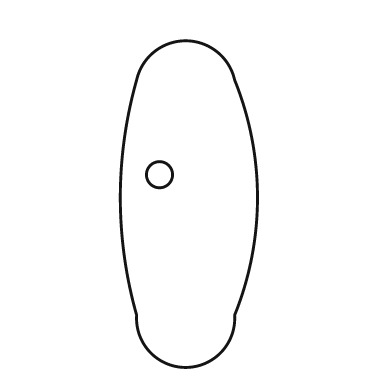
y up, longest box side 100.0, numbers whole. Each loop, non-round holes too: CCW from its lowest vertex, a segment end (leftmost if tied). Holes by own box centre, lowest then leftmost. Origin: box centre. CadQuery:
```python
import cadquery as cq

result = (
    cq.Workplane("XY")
    .moveTo(-16.0, -34.0)
    .threePointArc((-1.0, -50.0), (14.0, -34.0))
    .threePointArc((21.0, 2.0), (14.0, 38.0))
    .threePointArc((-1.0, 50.0), (-16.0, 38.0))
    .threePointArc((-21.0, 2.0), (-16.0, -34.0))
    .close()
    .moveTo(-9.0, 9.0)
    .circle(4.0)
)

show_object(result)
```